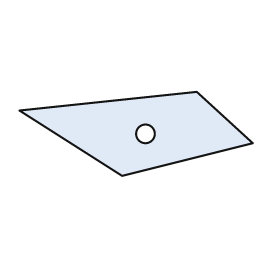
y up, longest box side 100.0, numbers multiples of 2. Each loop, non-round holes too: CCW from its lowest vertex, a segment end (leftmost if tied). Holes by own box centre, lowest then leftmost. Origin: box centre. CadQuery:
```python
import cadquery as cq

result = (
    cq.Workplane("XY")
    .moveTo(-6.0, -18.0)
    .lineTo(50.0, -4.0)
    .lineTo(26.0, 18.0)
    .lineTo(-50.0, 10.0)
    .close()
    .moveTo(4.0, 0.0)
    .circle(4.0)
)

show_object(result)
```